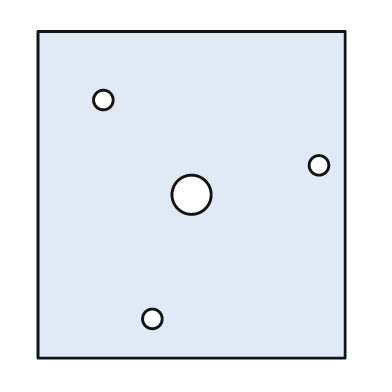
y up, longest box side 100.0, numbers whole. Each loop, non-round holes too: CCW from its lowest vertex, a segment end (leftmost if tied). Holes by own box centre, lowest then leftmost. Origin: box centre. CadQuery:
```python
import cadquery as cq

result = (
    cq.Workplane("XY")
    .moveTo(-47.0, -50.0)
    .lineTo(47.0, -50.0)
    .lineTo(47.0, 50.0)
    .lineTo(-47.0, 50.0)
    .close()
    .moveTo(-12.0, -38.0)
    .circle(3.0)
    .moveTo(0.0, 0.0)
    .circle(6.0)
    .moveTo(39.0, 9.0)
    .circle(3.0)
    .moveTo(-27.0, 29.0)
    .circle(3.0)
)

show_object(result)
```